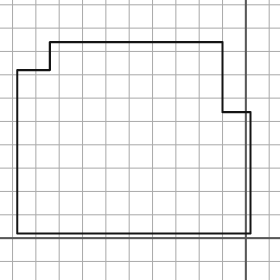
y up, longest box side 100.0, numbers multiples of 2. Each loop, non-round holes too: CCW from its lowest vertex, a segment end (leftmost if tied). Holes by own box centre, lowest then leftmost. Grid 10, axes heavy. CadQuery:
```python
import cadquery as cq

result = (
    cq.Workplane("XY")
    .moveTo(-98.0, 2.0)
    .lineTo(2.0, 2.0)
    .lineTo(2.0, 54.0)
    .lineTo(-10.0, 54.0)
    .lineTo(-10.0, 84.0)
    .lineTo(-84.0, 84.0)
    .lineTo(-84.0, 72.0)
    .lineTo(-98.0, 72.0)
    .close()
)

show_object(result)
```